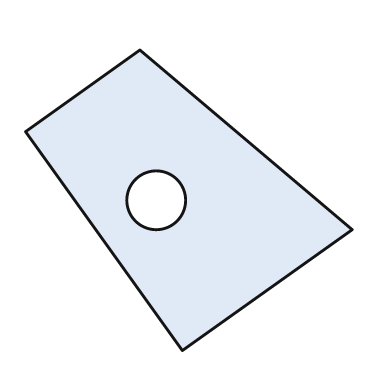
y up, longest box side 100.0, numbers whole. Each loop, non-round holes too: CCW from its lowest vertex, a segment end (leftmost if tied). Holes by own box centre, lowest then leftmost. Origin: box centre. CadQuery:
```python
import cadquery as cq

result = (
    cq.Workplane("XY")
    .moveTo(-2.0, -46.0)
    .lineTo(50.0, -9.0)
    .lineTo(-15.0, 46.0)
    .lineTo(-50.0, 21.0)
    .close()
    .moveTo(-10.0, 0.0)
    .circle(9.0)
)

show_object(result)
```